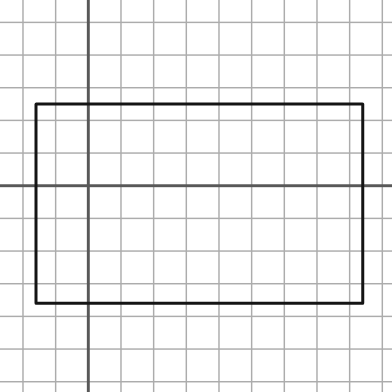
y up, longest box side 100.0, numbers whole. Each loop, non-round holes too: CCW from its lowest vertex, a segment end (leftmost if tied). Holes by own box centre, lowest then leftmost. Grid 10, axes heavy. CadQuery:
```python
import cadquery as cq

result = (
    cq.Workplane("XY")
    .moveTo(-16.0, -36.0)
    .lineTo(84.0, -36.0)
    .lineTo(84.0, 25.0)
    .lineTo(-16.0, 25.0)
    .close()
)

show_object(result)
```